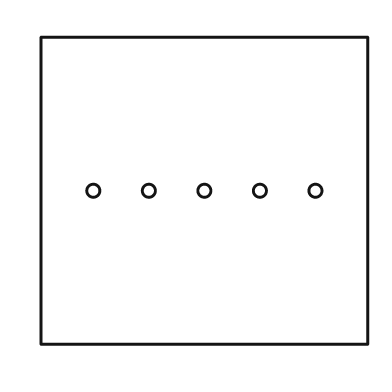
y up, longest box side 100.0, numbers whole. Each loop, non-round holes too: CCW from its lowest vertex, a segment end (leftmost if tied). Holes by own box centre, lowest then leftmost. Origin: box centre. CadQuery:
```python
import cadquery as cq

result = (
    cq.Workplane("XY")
    .moveTo(-50.0, -47.0)
    .lineTo(50.0, -47.0)
    .lineTo(50.0, 47.0)
    .lineTo(-50.0, 47.0)
    .close()
    .moveTo(-34.0, 0.0)
    .circle(2.0)
    .moveTo(-17.0, 0.0)
    .circle(2.0)
    .moveTo(0.0, 0.0)
    .circle(2.0)
    .moveTo(17.0, 0.0)
    .circle(2.0)
    .moveTo(34.0, 0.0)
    .circle(2.0)
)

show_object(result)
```